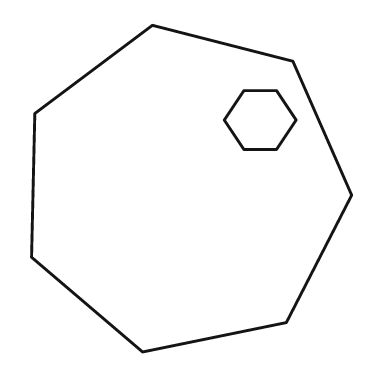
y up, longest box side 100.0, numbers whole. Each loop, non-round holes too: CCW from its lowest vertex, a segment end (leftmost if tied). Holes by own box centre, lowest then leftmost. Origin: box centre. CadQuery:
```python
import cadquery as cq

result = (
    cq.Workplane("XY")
    .moveTo(-15.0, -50.0)
    .lineTo(29.0, -41.0)
    .lineTo(49.0, -2.0)
    .lineTo(31.0, 39.0)
    .lineTo(-12.0, 50.0)
    .lineTo(-48.0, 23.0)
    .lineTo(-49.0, -21.0)
    .close()
    .moveTo(16.0, 12.0)
    .lineTo(26.0, 12.0)
    .lineTo(32.0, 21.0)
    .lineTo(26.0, 30.0)
    .lineTo(16.0, 30.0)
    .lineTo(10.0, 21.0)
    .close()
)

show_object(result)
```